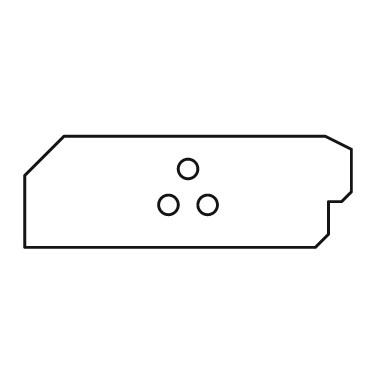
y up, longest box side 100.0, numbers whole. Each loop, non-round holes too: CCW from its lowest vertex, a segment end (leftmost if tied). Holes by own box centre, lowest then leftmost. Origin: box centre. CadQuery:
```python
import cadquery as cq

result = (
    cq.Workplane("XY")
    .moveTo(-50.0, -17.0)
    .lineTo(39.0, -17.0)
    .lineTo(43.0, -13.0)
    .lineTo(43.0, -3.0)
    .lineTo(47.0, -3.0)
    .lineTo(50.0, 0.0)
    .lineTo(50.0, 13.0)
    .lineTo(42.0, 17.0)
    .lineTo(-38.0, 17.0)
    .lineTo(-50.0, 5.0)
    .close()
    .moveTo(-6.0, -4.0)
    .circle(3.0)
    .moveTo(6.0, -4.0)
    .circle(3.0)
    .moveTo(0.0, 7.0)
    .circle(3.0)
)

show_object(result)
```